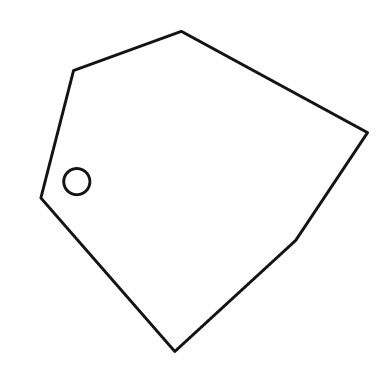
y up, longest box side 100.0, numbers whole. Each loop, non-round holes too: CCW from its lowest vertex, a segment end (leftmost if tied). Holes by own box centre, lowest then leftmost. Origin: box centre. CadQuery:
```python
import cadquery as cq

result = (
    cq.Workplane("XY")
    .moveTo(-9.0, -49.0)
    .lineTo(28.0, -15.0)
    .lineTo(50.0, 18.0)
    .lineTo(-7.0, 49.0)
    .lineTo(-40.0, 37.0)
    .lineTo(-50.0, -2.0)
    .close()
    .moveTo(-39.0, 3.0)
    .circle(4.0)
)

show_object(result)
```